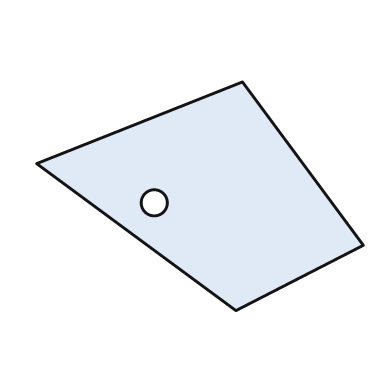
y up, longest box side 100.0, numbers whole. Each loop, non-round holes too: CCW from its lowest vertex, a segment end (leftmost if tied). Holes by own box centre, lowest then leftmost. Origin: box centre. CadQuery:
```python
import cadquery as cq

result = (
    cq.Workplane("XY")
    .moveTo(11.0, -35.0)
    .lineTo(50.0, -15.0)
    .lineTo(13.0, 35.0)
    .lineTo(-50.0, 10.0)
    .close()
    .moveTo(-14.0, -2.0)
    .circle(4.0)
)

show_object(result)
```